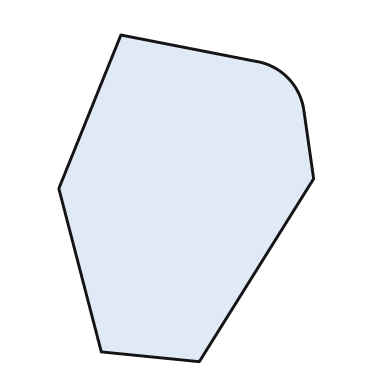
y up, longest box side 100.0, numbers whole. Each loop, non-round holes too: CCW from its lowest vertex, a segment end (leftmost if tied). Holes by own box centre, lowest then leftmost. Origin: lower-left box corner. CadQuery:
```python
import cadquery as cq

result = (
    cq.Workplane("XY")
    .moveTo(43.0, 0.0)
    .lineTo(78.0, 56.0)
    .lineTo(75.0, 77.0)
    .threePointArc((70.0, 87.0), (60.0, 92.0))
    .lineTo(19.0, 100.0)
    .lineTo(0.0, 53.0)
    .lineTo(13.0, 3.0)
    .close()
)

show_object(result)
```